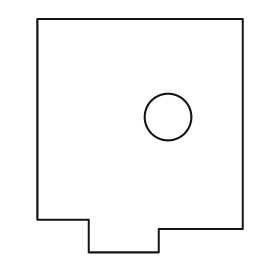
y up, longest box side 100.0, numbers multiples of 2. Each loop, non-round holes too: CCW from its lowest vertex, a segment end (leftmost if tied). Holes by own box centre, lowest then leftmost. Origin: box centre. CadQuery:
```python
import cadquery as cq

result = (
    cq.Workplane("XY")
    .moveTo(-22.0, -50.0)
    .lineTo(8.0, -50.0)
    .lineTo(8.0, -40.0)
    .lineTo(44.0, -40.0)
    .lineTo(44.0, 50.0)
    .lineTo(-44.0, 50.0)
    .lineTo(-44.0, -36.0)
    .lineTo(-22.0, -36.0)
    .close()
    .moveTo(12.0, 8.0)
    .circle(10.0)
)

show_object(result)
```